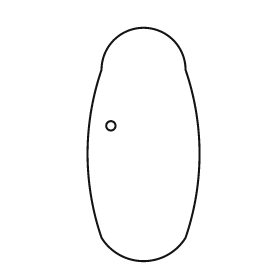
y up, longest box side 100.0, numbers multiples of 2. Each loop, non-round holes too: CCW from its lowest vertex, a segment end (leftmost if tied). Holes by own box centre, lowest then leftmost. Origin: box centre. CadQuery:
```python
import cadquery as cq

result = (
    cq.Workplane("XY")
    .moveTo(-18.0, -40.0)
    .threePointArc((0.0, -50.0), (18.0, -40.0))
    .threePointArc((24.0, -4.0), (18.0, 32.0))
    .threePointArc((0.0, 50.0), (-18.0, 32.0))
    .threePointArc((-24.0, -4.0), (-18.0, -40.0))
    .close()
    .moveTo(-14.0, 8.0)
    .circle(2.0)
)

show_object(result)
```